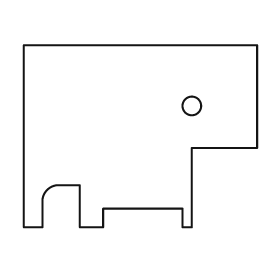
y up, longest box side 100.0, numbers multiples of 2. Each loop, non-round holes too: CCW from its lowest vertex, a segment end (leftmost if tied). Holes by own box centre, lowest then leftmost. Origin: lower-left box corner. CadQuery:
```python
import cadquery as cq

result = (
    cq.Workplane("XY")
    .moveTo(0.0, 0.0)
    .lineTo(8.0, 0.0)
    .lineTo(8.0, 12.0)
    .threePointArc((10.0, 16.0), (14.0, 18.0))
    .lineTo(24.0, 18.0)
    .lineTo(24.0, 0.0)
    .lineTo(34.0, 0.0)
    .lineTo(34.0, 8.0)
    .lineTo(68.0, 8.0)
    .lineTo(68.0, 0.0)
    .lineTo(72.0, 0.0)
    .lineTo(72.0, 34.0)
    .lineTo(100.0, 34.0)
    .lineTo(100.0, 78.0)
    .lineTo(0.0, 78.0)
    .close()
    .moveTo(72.0, 52.0)
    .circle(4.0)
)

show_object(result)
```